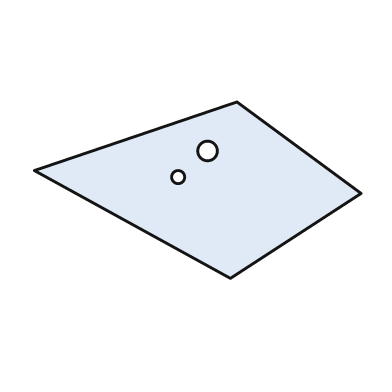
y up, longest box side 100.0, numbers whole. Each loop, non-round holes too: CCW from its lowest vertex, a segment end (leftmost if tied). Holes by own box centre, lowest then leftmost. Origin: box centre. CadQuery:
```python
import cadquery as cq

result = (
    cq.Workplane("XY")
    .moveTo(10.0, -27.0)
    .lineTo(50.0, -1.0)
    .lineTo(12.0, 27.0)
    .lineTo(-50.0, 6.0)
    .close()
    .moveTo(-6.0, 4.0)
    .circle(2.0)
    .moveTo(3.0, 12.0)
    .circle(3.0)
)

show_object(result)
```